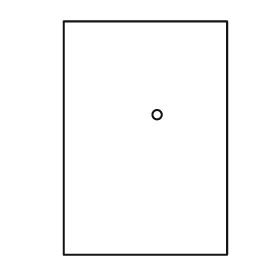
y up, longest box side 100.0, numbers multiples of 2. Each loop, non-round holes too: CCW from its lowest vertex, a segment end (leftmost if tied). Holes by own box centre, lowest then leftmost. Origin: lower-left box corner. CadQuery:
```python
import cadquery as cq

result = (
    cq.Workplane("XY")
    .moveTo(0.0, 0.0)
    .lineTo(70.0, 0.0)
    .lineTo(70.0, 100.0)
    .lineTo(0.0, 100.0)
    .close()
    .moveTo(40.0, 60.0)
    .circle(2.0)
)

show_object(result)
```